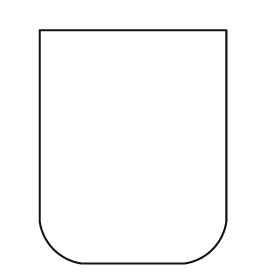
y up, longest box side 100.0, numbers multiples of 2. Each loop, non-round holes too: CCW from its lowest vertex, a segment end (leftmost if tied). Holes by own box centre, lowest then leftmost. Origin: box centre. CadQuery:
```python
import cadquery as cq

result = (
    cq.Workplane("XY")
    .moveTo(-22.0, -50.0)
    .lineTo(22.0, -50.0)
    .threePointArc((34.0, -44.0), (40.0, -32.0))
    .lineTo(40.0, 50.0)
    .lineTo(-40.0, 50.0)
    .lineTo(-40.0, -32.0)
    .threePointArc((-34.0, -44.0), (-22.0, -50.0))
    .close()
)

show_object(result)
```